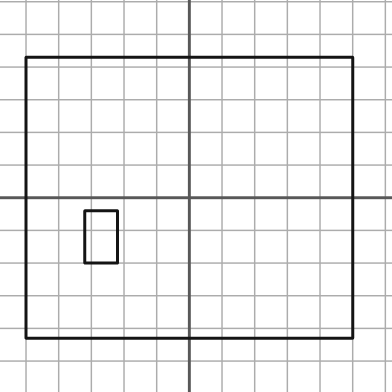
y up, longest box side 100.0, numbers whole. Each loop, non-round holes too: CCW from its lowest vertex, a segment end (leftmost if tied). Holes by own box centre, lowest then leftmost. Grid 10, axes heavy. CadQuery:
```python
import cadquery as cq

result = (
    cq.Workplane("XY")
    .moveTo(-50.0, -43.0)
    .lineTo(50.0, -43.0)
    .lineTo(50.0, 43.0)
    .lineTo(-50.0, 43.0)
    .close()
    .moveTo(-32.0, -20.0)
    .lineTo(-22.0, -20.0)
    .lineTo(-22.0, -4.0)
    .lineTo(-32.0, -4.0)
    .close()
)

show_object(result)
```